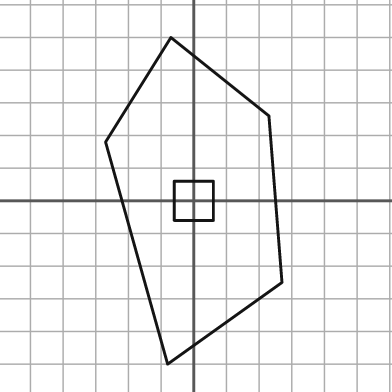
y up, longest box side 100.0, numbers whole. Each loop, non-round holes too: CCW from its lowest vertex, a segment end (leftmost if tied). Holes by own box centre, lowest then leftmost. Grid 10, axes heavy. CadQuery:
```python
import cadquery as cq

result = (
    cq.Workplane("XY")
    .moveTo(-8.0, -50.0)
    .lineTo(27.0, -25.0)
    .lineTo(23.0, 26.0)
    .lineTo(-7.0, 50.0)
    .lineTo(-27.0, 18.0)
    .close()
    .moveTo(-6.0, -6.0)
    .lineTo(6.0, -6.0)
    .lineTo(6.0, 6.0)
    .lineTo(-6.0, 6.0)
    .close()
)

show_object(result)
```